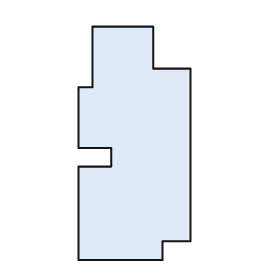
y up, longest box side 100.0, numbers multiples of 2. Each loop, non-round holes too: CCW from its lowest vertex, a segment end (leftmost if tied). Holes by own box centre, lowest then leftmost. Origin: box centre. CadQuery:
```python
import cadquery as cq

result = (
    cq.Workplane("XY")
    .moveTo(-24.0, -50.0)
    .lineTo(12.0, -50.0)
    .lineTo(12.0, -42.0)
    .lineTo(24.0, -42.0)
    .lineTo(24.0, 32.0)
    .lineTo(8.0, 32.0)
    .lineTo(8.0, 50.0)
    .lineTo(-18.0, 50.0)
    .lineTo(-18.0, 24.0)
    .lineTo(-24.0, 24.0)
    .lineTo(-24.0, -2.0)
    .lineTo(-10.0, -2.0)
    .lineTo(-10.0, -10.0)
    .lineTo(-24.0, -10.0)
    .close()
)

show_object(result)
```